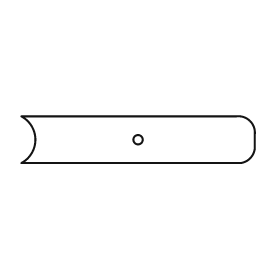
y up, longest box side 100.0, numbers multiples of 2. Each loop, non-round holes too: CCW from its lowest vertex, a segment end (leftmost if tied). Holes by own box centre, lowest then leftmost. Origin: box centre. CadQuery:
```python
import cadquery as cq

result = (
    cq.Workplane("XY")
    .moveTo(-50.0, -10.0)
    .lineTo(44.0, -10.0)
    .threePointArc((48.0, -8.0), (50.0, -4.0))
    .lineTo(50.0, 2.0)
    .threePointArc((48.0, 8.0), (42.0, 10.0))
    .lineTo(-50.0, 10.0)
    .threePointArc((-44.0, 0.0), (-50.0, -10.0))
    .close()
    .moveTo(0.0, 0.0)
    .circle(2.0)
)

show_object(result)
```